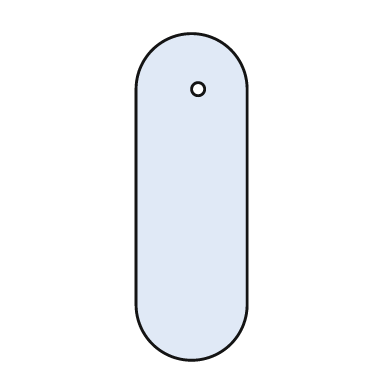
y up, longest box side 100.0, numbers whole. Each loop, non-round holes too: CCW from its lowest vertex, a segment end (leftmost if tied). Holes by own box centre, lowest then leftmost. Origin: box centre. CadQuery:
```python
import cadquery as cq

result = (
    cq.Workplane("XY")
    .moveTo(-17.0, -33.0)
    .threePointArc((0.0, -50.0), (17.0, -33.0))
    .lineTo(17.0, 33.0)
    .threePointArc((0.0, 50.0), (-17.0, 33.0))
    .close()
    .moveTo(2.0, 33.0)
    .circle(2.0)
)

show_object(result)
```